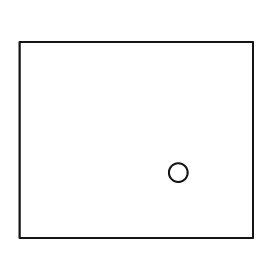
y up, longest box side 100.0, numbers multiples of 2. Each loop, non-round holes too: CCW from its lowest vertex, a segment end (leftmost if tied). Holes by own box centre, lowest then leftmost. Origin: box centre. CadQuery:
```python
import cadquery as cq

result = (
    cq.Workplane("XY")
    .moveTo(-50.0, -42.0)
    .lineTo(50.0, -42.0)
    .lineTo(50.0, 42.0)
    .lineTo(-50.0, 42.0)
    .close()
    .moveTo(18.0, -14.0)
    .circle(4.0)
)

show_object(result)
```